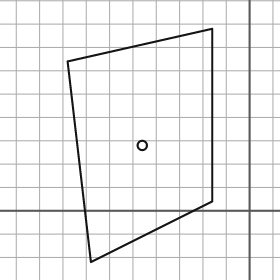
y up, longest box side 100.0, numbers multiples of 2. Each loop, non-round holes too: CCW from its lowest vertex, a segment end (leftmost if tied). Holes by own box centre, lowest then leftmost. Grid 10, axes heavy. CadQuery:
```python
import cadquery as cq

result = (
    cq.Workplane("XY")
    .moveTo(-68.0, -22.0)
    .lineTo(-16.0, 4.0)
    .lineTo(-16.0, 78.0)
    .lineTo(-78.0, 64.0)
    .close()
    .moveTo(-46.0, 28.0)
    .circle(2.0)
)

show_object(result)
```